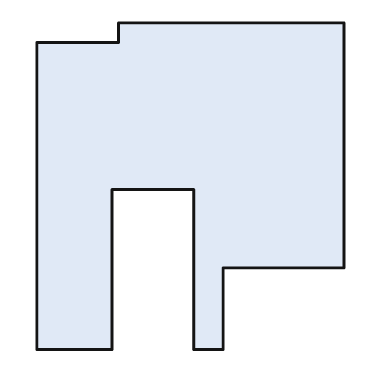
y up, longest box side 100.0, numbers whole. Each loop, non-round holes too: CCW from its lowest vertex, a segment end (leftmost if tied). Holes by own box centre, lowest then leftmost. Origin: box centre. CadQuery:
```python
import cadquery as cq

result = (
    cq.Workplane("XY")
    .moveTo(-47.0, -50.0)
    .lineTo(-24.0, -50.0)
    .lineTo(-24.0, -1.0)
    .lineTo(1.0, -1.0)
    .lineTo(1.0, -50.0)
    .lineTo(10.0, -50.0)
    .lineTo(10.0, -25.0)
    .lineTo(47.0, -25.0)
    .lineTo(47.0, 50.0)
    .lineTo(-22.0, 50.0)
    .lineTo(-22.0, 44.0)
    .lineTo(-47.0, 44.0)
    .close()
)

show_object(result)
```